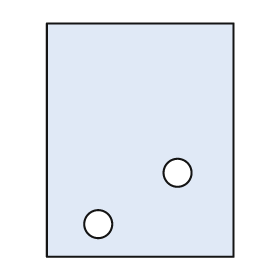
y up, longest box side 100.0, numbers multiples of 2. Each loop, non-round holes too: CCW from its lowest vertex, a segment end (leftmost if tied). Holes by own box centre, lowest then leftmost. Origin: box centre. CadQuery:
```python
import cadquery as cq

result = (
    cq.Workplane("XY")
    .moveTo(-40.0, -50.0)
    .lineTo(40.0, -50.0)
    .lineTo(40.0, 50.0)
    .lineTo(-40.0, 50.0)
    .close()
    .moveTo(-18.0, -36.0)
    .circle(6.0)
    .moveTo(16.0, -14.0)
    .circle(6.0)
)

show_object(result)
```